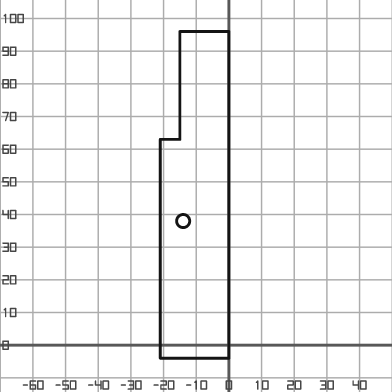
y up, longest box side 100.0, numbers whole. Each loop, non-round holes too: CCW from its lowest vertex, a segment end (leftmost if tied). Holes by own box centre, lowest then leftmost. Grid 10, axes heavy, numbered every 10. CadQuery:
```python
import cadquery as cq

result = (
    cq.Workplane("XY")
    .moveTo(-21.0, -4.0)
    .lineTo(0.0, -4.0)
    .lineTo(0.0, 96.0)
    .lineTo(-15.0, 96.0)
    .lineTo(-15.0, 63.0)
    .lineTo(-21.0, 63.0)
    .close()
    .moveTo(-14.0, 38.0)
    .circle(2.0)
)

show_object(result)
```